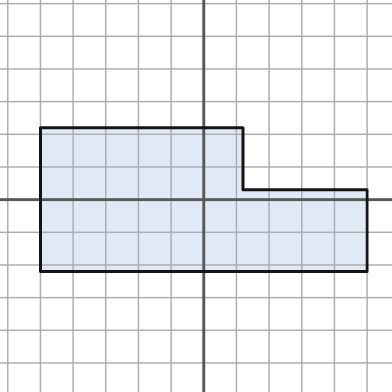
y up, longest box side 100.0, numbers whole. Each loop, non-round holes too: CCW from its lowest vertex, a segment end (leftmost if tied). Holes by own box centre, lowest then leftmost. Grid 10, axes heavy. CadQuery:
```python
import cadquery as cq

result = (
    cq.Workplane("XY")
    .moveTo(-50.0, -22.0)
    .lineTo(50.0, -22.0)
    .lineTo(50.0, 3.0)
    .lineTo(12.0, 3.0)
    .lineTo(12.0, 22.0)
    .lineTo(-50.0, 22.0)
    .close()
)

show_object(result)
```